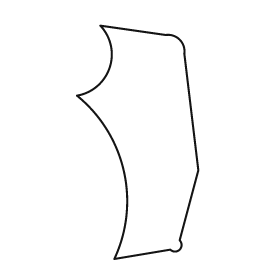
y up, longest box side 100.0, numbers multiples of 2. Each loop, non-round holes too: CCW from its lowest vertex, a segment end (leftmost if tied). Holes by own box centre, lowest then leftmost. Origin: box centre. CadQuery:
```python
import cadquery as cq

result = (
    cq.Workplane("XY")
    .moveTo(-10.0, -50.0)
    .lineTo(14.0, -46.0)
    .threePointArc((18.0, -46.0), (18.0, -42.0))
    .lineTo(26.0, -12.0)
    .lineTo(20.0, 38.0)
    .threePointArc((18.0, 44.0), (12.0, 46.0))
    .lineTo(-16.0, 50.0)
    .threePointArc((-12.0, 32.0), (-26.0, 20.0))
    .threePointArc((-6.0, -12.0), (-10.0, -50.0))
    .close()
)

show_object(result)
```